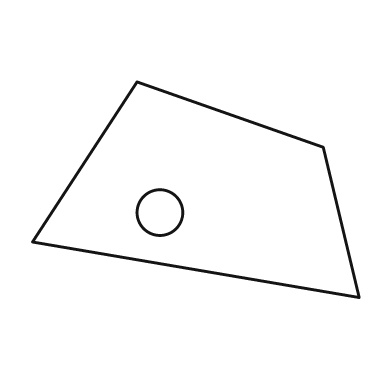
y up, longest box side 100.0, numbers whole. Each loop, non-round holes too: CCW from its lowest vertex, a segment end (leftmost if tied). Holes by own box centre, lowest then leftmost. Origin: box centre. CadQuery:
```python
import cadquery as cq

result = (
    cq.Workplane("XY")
    .moveTo(50.0, -33.0)
    .lineTo(39.0, 13.0)
    .lineTo(-18.0, 33.0)
    .lineTo(-50.0, -16.0)
    .close()
    .moveTo(-11.0, -7.0)
    .circle(7.0)
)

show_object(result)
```